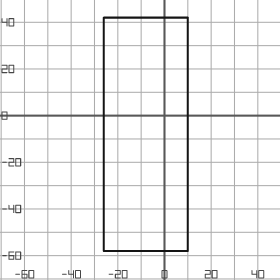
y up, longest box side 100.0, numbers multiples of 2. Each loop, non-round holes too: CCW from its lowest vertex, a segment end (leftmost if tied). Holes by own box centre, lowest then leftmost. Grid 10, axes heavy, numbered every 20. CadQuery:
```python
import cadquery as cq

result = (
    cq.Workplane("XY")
    .moveTo(-26.0, -58.0)
    .lineTo(10.0, -58.0)
    .lineTo(10.0, 42.0)
    .lineTo(-26.0, 42.0)
    .close()
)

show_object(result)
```